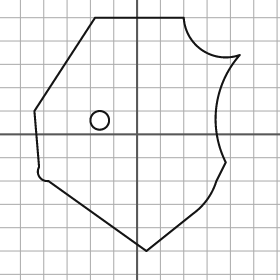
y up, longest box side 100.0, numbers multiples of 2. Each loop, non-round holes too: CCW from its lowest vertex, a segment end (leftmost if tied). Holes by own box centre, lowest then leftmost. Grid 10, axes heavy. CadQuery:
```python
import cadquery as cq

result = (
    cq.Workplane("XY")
    .moveTo(4.0, -50.0)
    .lineTo(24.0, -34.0)
    .threePointArc((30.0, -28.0), (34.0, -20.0))
    .lineTo(38.0, -12.0)
    .threePointArc((34.0, 12.0), (44.0, 34.0))
    .threePointArc((28.0, 36.0), (20.0, 50.0))
    .lineTo(-18.0, 50.0)
    .lineTo(-44.0, 10.0)
    .lineTo(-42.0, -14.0)
    .threePointArc((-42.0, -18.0), (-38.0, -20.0))
    .close()
    .moveTo(-16.0, 6.0)
    .circle(4.0)
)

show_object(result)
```